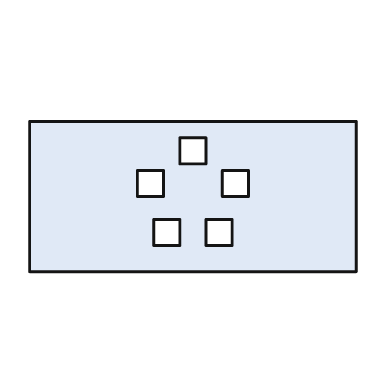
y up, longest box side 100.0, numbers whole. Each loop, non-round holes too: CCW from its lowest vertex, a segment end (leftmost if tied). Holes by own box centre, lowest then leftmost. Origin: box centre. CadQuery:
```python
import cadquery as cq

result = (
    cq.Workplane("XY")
    .moveTo(-50.0, -23.0)
    .lineTo(50.0, -23.0)
    .lineTo(50.0, 23.0)
    .lineTo(-50.0, 23.0)
    .close()
    .moveTo(-12.0, -15.0)
    .lineTo(-4.0, -15.0)
    .lineTo(-4.0, -7.0)
    .lineTo(-12.0, -7.0)
    .close()
    .moveTo(4.0, -15.0)
    .lineTo(12.0, -15.0)
    .lineTo(12.0, -7.0)
    .lineTo(4.0, -7.0)
    .close()
    .moveTo(-17.0, 0.0)
    .lineTo(-9.0, 0.0)
    .lineTo(-9.0, 8.0)
    .lineTo(-17.0, 8.0)
    .close()
    .moveTo(9.0, 0.0)
    .lineTo(17.0, 0.0)
    .lineTo(17.0, 8.0)
    .lineTo(9.0, 8.0)
    .close()
    .moveTo(-4.0, 10.0)
    .lineTo(4.0, 10.0)
    .lineTo(4.0, 18.0)
    .lineTo(-4.0, 18.0)
    .close()
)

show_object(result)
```